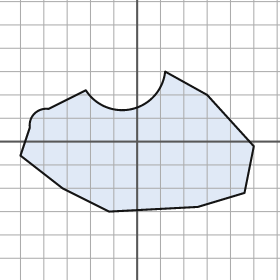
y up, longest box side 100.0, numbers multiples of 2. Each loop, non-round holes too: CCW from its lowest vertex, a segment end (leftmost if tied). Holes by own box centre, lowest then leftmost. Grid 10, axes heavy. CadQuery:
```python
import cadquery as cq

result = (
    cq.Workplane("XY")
    .moveTo(-12.0, -30.0)
    .lineTo(26.0, -28.0)
    .lineTo(46.0, -22.0)
    .lineTo(50.0, -2.0)
    .lineTo(30.0, 20.0)
    .lineTo(12.0, 30.0)
    .threePointArc((-2.0, 14.0), (-22.0, 22.0))
    .lineTo(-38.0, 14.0)
    .threePointArc((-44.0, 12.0), (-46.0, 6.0))
    .lineTo(-50.0, -6.0)
    .lineTo(-32.0, -20.0)
    .close()
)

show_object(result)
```